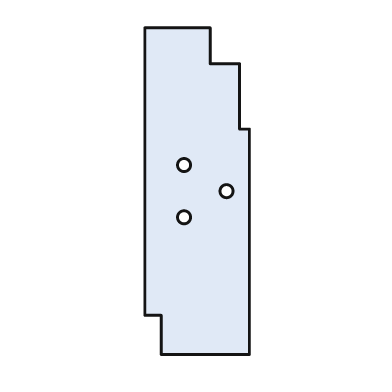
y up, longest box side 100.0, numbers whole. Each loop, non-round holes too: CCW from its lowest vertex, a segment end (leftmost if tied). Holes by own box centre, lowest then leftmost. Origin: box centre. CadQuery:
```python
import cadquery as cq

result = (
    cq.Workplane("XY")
    .moveTo(-11.0, -50.0)
    .lineTo(16.0, -50.0)
    .lineTo(16.0, 19.0)
    .lineTo(13.0, 19.0)
    .lineTo(13.0, 39.0)
    .lineTo(4.0, 39.0)
    .lineTo(4.0, 50.0)
    .lineTo(-16.0, 50.0)
    .lineTo(-16.0, -38.0)
    .lineTo(-11.0, -38.0)
    .close()
    .moveTo(-4.0, -8.0)
    .circle(2.0)
    .moveTo(9.0, 0.0)
    .circle(2.0)
    .moveTo(-4.0, 8.0)
    .circle(2.0)
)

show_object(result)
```